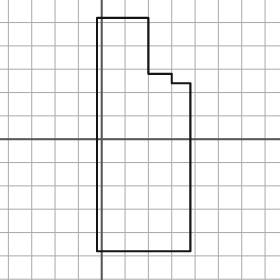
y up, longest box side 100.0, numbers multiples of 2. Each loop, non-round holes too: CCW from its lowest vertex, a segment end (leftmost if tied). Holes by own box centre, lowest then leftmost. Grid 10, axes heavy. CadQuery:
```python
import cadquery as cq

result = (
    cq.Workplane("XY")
    .moveTo(-2.0, -48.0)
    .lineTo(38.0, -48.0)
    .lineTo(38.0, 24.0)
    .lineTo(30.0, 24.0)
    .lineTo(30.0, 28.0)
    .lineTo(20.0, 28.0)
    .lineTo(20.0, 52.0)
    .lineTo(-2.0, 52.0)
    .close()
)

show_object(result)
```